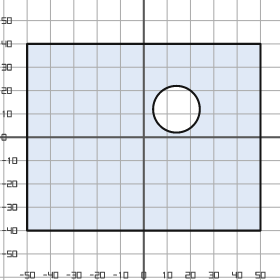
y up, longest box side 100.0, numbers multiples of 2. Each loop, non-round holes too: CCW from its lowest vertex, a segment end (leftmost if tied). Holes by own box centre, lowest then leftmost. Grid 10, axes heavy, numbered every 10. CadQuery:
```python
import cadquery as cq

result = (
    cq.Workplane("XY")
    .moveTo(-50.0, -40.0)
    .lineTo(50.0, -40.0)
    .lineTo(50.0, 40.0)
    .lineTo(-50.0, 40.0)
    .close()
    .moveTo(14.0, 12.0)
    .circle(10.0)
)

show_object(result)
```